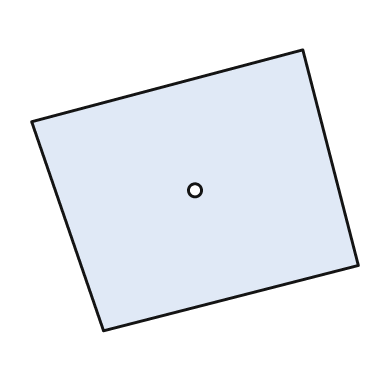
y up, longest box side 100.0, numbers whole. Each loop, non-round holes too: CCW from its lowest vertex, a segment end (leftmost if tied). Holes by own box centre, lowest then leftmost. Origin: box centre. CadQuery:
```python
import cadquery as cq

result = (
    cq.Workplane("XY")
    .moveTo(-28.0, -43.0)
    .lineTo(50.0, -23.0)
    .lineTo(33.0, 43.0)
    .lineTo(-50.0, 21.0)
    .close()
    .moveTo(0.0, 0.0)
    .circle(2.0)
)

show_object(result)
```